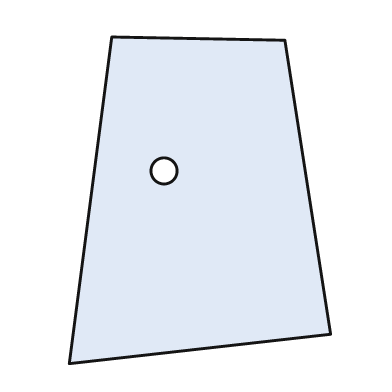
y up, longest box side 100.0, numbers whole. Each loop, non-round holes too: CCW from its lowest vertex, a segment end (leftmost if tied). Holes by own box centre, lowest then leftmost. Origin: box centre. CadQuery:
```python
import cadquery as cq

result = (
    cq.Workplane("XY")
    .moveTo(-40.0, -50.0)
    .lineTo(40.0, -41.0)
    .lineTo(26.0, 49.0)
    .lineTo(-27.0, 50.0)
    .close()
    .moveTo(-11.0, 9.0)
    .circle(4.0)
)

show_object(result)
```